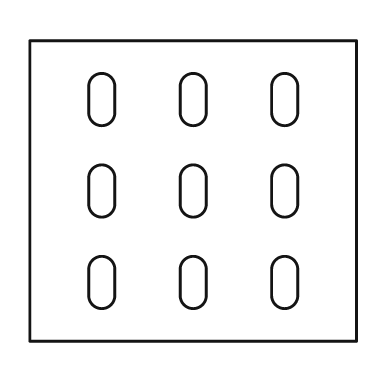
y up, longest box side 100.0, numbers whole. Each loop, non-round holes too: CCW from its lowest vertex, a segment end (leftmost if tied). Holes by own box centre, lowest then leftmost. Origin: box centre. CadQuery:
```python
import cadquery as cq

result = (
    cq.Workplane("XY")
    .moveTo(-50.0, -46.0)
    .lineTo(50.0, -46.0)
    .lineTo(50.0, 46.0)
    .lineTo(-50.0, 46.0)
    .close()
    .moveTo(-32.0, -32.0)
    .threePointArc((-28.0, -36.0), (-24.0, -32.0))
    .lineTo(-24.0, -24.0)
    .threePointArc((-28.0, -20.0), (-32.0, -24.0))
    .close()
    .moveTo(-4.0, -32.0)
    .threePointArc((0.0, -36.0), (4.0, -32.0))
    .lineTo(4.0, -24.0)
    .threePointArc((0.0, -20.0), (-4.0, -24.0))
    .close()
    .moveTo(24.0, -32.0)
    .threePointArc((28.0, -36.0), (32.0, -32.0))
    .lineTo(32.0, -24.0)
    .threePointArc((28.0, -20.0), (24.0, -24.0))
    .close()
    .moveTo(-32.0, -4.0)
    .threePointArc((-28.0, -8.0), (-24.0, -4.0))
    .lineTo(-24.0, 4.0)
    .threePointArc((-28.0, 8.0), (-32.0, 4.0))
    .close()
    .moveTo(-4.0, -4.0)
    .threePointArc((0.0, -8.0), (4.0, -4.0))
    .lineTo(4.0, 4.0)
    .threePointArc((0.0, 8.0), (-4.0, 4.0))
    .close()
    .moveTo(24.0, -4.0)
    .threePointArc((28.0, -8.0), (32.0, -4.0))
    .lineTo(32.0, 4.0)
    .threePointArc((28.0, 8.0), (24.0, 4.0))
    .close()
    .moveTo(-32.0, 24.0)
    .threePointArc((-28.0, 20.0), (-24.0, 24.0))
    .lineTo(-24.0, 32.0)
    .threePointArc((-28.0, 36.0), (-32.0, 32.0))
    .close()
    .moveTo(-4.0, 24.0)
    .threePointArc((0.0, 20.0), (4.0, 24.0))
    .lineTo(4.0, 32.0)
    .threePointArc((0.0, 36.0), (-4.0, 32.0))
    .close()
    .moveTo(24.0, 24.0)
    .threePointArc((28.0, 20.0), (32.0, 24.0))
    .lineTo(32.0, 32.0)
    .threePointArc((28.0, 36.0), (24.0, 32.0))
    .close()
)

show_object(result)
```